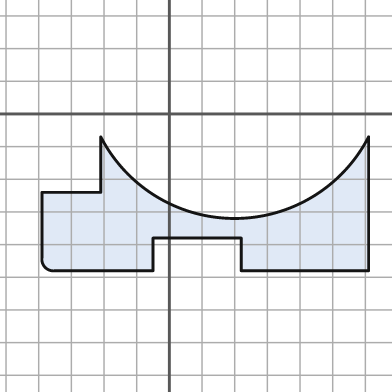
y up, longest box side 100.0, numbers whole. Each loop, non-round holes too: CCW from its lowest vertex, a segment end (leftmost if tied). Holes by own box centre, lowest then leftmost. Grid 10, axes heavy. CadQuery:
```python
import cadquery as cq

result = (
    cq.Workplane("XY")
    .moveTo(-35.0, -48.0)
    .lineTo(-5.0, -48.0)
    .lineTo(-5.0, -38.0)
    .lineTo(22.0, -38.0)
    .lineTo(22.0, -48.0)
    .lineTo(61.0, -48.0)
    .lineTo(61.0, -7.0)
    .threePointArc((20.0, -32.0), (-21.0, -7.0))
    .lineTo(-21.0, -24.0)
    .lineTo(-39.0, -24.0)
    .lineTo(-39.0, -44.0)
    .threePointArc((-38.0, -47.0), (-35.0, -48.0))
    .close()
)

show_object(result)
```